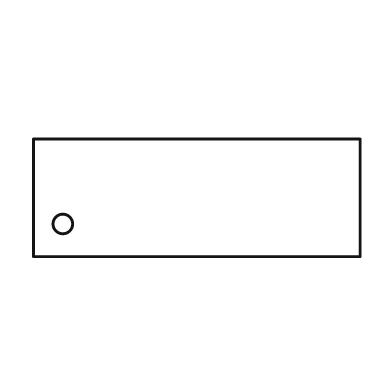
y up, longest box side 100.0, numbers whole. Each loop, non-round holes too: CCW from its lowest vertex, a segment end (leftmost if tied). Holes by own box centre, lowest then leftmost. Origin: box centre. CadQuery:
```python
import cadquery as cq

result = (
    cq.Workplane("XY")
    .moveTo(-50.0, -18.0)
    .lineTo(50.0, -18.0)
    .lineTo(50.0, 18.0)
    .lineTo(-50.0, 18.0)
    .close()
    .moveTo(-41.0, -8.0)
    .circle(3.0)
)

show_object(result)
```